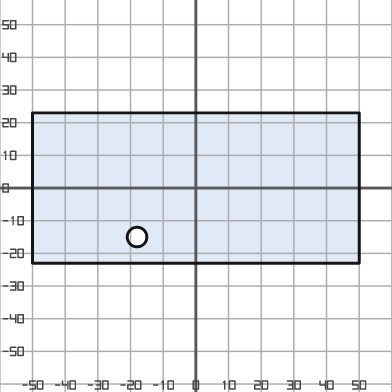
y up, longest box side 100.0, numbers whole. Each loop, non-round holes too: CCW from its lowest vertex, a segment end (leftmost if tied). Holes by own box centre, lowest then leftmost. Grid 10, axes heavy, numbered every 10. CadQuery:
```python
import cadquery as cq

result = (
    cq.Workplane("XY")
    .moveTo(-50.0, -23.0)
    .lineTo(50.0, -23.0)
    .lineTo(50.0, 23.0)
    .lineTo(-50.0, 23.0)
    .close()
    .moveTo(-18.0, -15.0)
    .circle(3.0)
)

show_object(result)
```